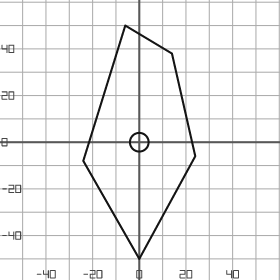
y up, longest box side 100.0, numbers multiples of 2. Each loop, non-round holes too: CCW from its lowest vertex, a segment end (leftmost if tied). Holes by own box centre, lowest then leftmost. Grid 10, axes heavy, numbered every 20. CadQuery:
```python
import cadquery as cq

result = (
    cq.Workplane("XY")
    .moveTo(0.0, -50.0)
    .lineTo(24.0, -6.0)
    .lineTo(14.0, 38.0)
    .lineTo(-6.0, 50.0)
    .lineTo(-24.0, -8.0)
    .close()
    .moveTo(0.0, 0.0)
    .circle(4.0)
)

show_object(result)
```